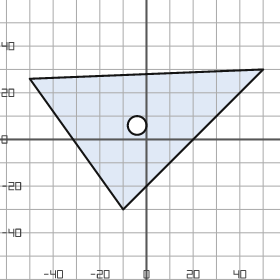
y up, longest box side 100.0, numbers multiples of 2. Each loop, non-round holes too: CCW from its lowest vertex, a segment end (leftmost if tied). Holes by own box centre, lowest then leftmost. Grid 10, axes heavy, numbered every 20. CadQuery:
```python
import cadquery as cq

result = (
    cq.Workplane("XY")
    .moveTo(-10.0, -30.0)
    .lineTo(50.0, 30.0)
    .lineTo(-50.0, 26.0)
    .close()
    .moveTo(-4.0, 6.0)
    .circle(4.0)
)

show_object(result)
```